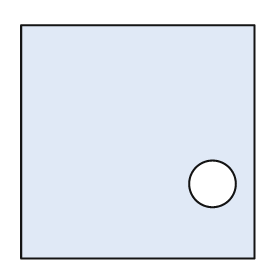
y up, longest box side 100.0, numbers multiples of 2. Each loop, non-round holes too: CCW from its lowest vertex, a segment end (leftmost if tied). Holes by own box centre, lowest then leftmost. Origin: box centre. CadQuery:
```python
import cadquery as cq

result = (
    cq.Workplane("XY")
    .moveTo(-50.0, -50.0)
    .lineTo(50.0, -50.0)
    .lineTo(50.0, 50.0)
    .lineTo(-50.0, 50.0)
    .close()
    .moveTo(32.0, -18.0)
    .circle(10.0)
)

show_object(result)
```